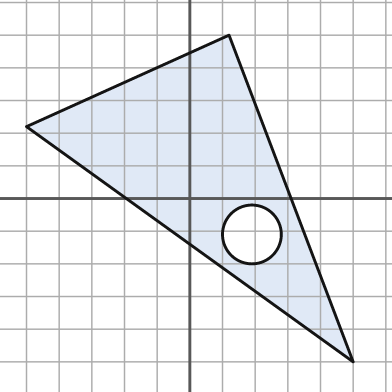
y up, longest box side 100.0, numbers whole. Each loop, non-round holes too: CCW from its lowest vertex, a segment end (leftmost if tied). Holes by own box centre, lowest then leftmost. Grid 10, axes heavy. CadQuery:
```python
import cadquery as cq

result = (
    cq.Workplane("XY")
    .moveTo(50.0, -50.0)
    .lineTo(12.0, 50.0)
    .lineTo(-50.0, 22.0)
    .close()
    .moveTo(19.0, -11.0)
    .circle(9.0)
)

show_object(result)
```